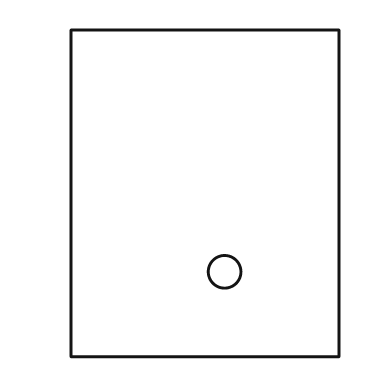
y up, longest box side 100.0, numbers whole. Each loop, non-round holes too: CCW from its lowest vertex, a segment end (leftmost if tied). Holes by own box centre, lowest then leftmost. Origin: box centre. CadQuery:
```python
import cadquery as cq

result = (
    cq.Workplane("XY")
    .moveTo(-41.0, -50.0)
    .lineTo(41.0, -50.0)
    .lineTo(41.0, 50.0)
    .lineTo(-41.0, 50.0)
    .close()
    .moveTo(6.0, -24.0)
    .circle(5.0)
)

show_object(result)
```